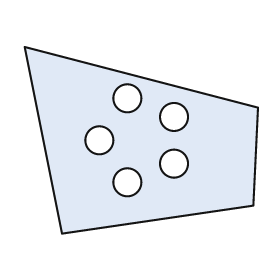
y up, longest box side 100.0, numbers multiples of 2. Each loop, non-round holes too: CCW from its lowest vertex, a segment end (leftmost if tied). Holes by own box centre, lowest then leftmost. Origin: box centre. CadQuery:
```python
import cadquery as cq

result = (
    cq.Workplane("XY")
    .moveTo(-34.0, -40.0)
    .lineTo(48.0, -28.0)
    .lineTo(50.0, 14.0)
    .lineTo(-50.0, 40.0)
    .close()
    .moveTo(-6.0, -18.0)
    .circle(6.0)
    .moveTo(14.0, -10.0)
    .circle(6.0)
    .moveTo(-18.0, 0.0)
    .circle(6.0)
    .moveTo(14.0, 10.0)
    .circle(6.0)
    .moveTo(-6.0, 18.0)
    .circle(6.0)
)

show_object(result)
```